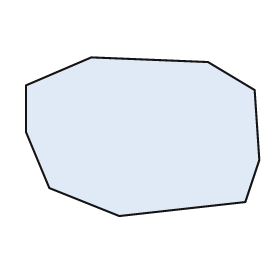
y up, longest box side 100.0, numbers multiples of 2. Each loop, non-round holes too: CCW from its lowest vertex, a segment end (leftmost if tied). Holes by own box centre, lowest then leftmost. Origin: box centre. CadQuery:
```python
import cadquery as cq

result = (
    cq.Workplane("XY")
    .moveTo(-10.0, -34.0)
    .lineTo(44.0, -28.0)
    .lineTo(50.0, -10.0)
    .lineTo(48.0, 20.0)
    .lineTo(28.0, 32.0)
    .lineTo(-22.0, 34.0)
    .lineTo(-50.0, 22.0)
    .lineTo(-50.0, 2.0)
    .lineTo(-40.0, -22.0)
    .close()
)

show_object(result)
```